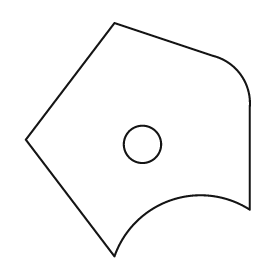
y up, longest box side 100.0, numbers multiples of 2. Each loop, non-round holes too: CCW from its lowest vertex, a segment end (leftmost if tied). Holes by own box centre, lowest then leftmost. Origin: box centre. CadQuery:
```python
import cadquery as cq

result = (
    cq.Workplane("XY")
    .moveTo(-10.0, -50.0)
    .threePointArc((14.0, -26.0), (48.0, -30.0))
    .lineTo(48.0, 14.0)
    .threePointArc((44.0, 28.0), (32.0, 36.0))
    .lineTo(-10.0, 50.0)
    .lineTo(-48.0, 0.0)
    .close()
    .moveTo(2.0, -2.0)
    .circle(8.0)
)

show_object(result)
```